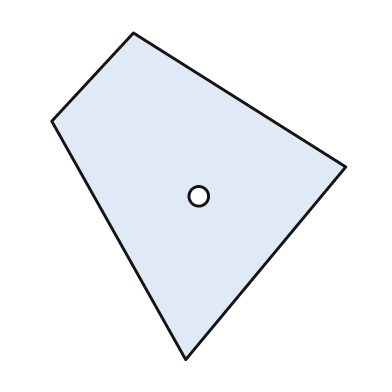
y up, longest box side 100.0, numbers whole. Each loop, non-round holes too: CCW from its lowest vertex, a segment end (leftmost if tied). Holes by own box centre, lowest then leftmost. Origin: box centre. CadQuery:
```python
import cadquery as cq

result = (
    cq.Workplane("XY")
    .moveTo(-4.0, -50.0)
    .lineTo(45.0, 9.0)
    .lineTo(-20.0, 50.0)
    .lineTo(-45.0, 23.0)
    .close()
    .moveTo(0.0, 0.0)
    .circle(3.0)
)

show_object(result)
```